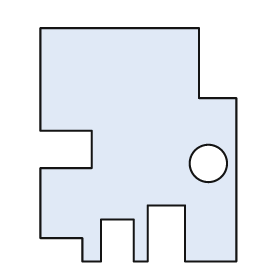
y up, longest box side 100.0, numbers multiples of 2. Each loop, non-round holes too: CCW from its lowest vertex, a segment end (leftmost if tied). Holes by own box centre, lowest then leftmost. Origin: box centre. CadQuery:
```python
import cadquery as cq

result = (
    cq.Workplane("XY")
    .moveTo(-24.0, -50.0)
    .lineTo(-16.0, -50.0)
    .lineTo(-16.0, -32.0)
    .lineTo(-2.0, -32.0)
    .lineTo(-2.0, -50.0)
    .lineTo(4.0, -50.0)
    .lineTo(4.0, -26.0)
    .lineTo(20.0, -26.0)
    .lineTo(20.0, -50.0)
    .lineTo(42.0, -50.0)
    .lineTo(42.0, 20.0)
    .lineTo(26.0, 20.0)
    .lineTo(26.0, 50.0)
    .lineTo(-42.0, 50.0)
    .lineTo(-42.0, 6.0)
    .lineTo(-20.0, 6.0)
    .lineTo(-20.0, -10.0)
    .lineTo(-42.0, -10.0)
    .lineTo(-42.0, -40.0)
    .lineTo(-24.0, -40.0)
    .close()
    .moveTo(30.0, -8.0)
    .circle(8.0)
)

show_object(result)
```